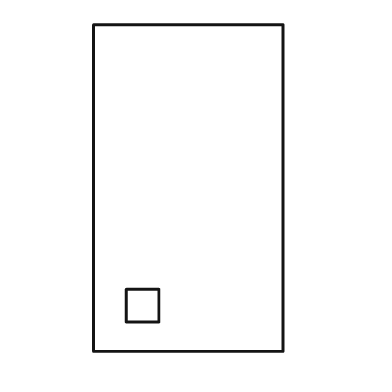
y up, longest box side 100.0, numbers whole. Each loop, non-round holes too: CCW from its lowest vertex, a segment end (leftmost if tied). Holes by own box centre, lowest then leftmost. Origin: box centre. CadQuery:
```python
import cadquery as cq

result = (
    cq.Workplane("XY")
    .moveTo(-29.0, -50.0)
    .lineTo(29.0, -50.0)
    .lineTo(29.0, 50.0)
    .lineTo(-29.0, 50.0)
    .close()
    .moveTo(-19.0, -41.0)
    .lineTo(-9.0, -41.0)
    .lineTo(-9.0, -31.0)
    .lineTo(-19.0, -31.0)
    .close()
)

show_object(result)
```